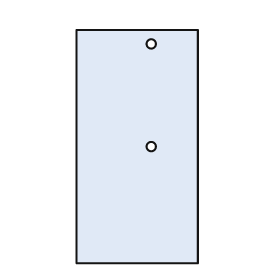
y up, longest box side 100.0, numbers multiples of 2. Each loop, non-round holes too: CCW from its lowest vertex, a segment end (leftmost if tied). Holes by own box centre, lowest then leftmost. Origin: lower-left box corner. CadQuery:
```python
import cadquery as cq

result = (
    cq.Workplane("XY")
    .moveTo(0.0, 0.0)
    .lineTo(52.0, 0.0)
    .lineTo(52.0, 100.0)
    .lineTo(0.0, 100.0)
    .close()
    .moveTo(32.0, 50.0)
    .circle(2.0)
    .moveTo(32.0, 94.0)
    .circle(2.0)
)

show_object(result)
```